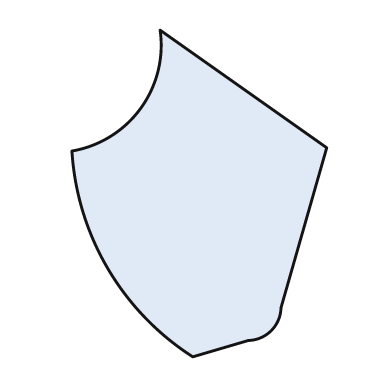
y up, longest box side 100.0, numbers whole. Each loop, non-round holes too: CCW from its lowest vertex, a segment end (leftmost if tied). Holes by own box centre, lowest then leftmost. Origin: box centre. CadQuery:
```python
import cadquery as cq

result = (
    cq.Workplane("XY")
    .moveTo(-2.0, -50.0)
    .lineTo(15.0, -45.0)
    .threePointArc((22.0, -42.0), (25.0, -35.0))
    .lineTo(39.0, 14.0)
    .lineTo(-12.0, 50.0)
    .threePointArc((-18.0, 26.0), (-39.0, 13.0))
    .threePointArc((-28.0, -23.0), (-2.0, -50.0))
    .close()
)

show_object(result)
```